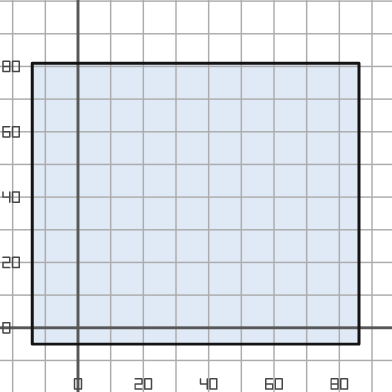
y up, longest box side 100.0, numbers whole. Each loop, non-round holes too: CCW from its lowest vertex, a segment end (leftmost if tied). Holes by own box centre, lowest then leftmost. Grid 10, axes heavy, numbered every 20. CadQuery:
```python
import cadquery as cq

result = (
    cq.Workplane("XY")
    .moveTo(-14.0, -5.0)
    .lineTo(86.0, -5.0)
    .lineTo(86.0, 81.0)
    .lineTo(-14.0, 81.0)
    .close()
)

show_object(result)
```